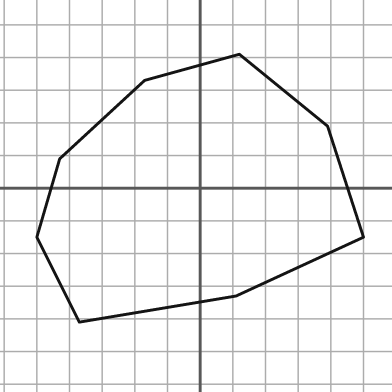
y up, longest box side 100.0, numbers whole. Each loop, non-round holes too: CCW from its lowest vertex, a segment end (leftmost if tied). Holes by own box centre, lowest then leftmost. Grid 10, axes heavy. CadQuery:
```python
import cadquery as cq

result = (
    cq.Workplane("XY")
    .moveTo(-37.0, -41.0)
    .lineTo(11.0, -33.0)
    .lineTo(50.0, -15.0)
    .lineTo(39.0, 19.0)
    .lineTo(12.0, 41.0)
    .lineTo(-17.0, 33.0)
    .lineTo(-43.0, 9.0)
    .lineTo(-50.0, -15.0)
    .close()
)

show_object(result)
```